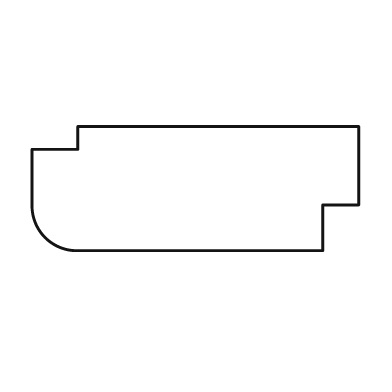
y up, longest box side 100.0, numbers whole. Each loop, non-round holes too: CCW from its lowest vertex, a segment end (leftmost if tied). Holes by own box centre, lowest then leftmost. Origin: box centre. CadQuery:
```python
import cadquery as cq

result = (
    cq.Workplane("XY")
    .moveTo(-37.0, -19.0)
    .lineTo(39.0, -19.0)
    .lineTo(39.0, -5.0)
    .lineTo(50.0, -5.0)
    .lineTo(50.0, 19.0)
    .lineTo(-36.0, 19.0)
    .lineTo(-36.0, 12.0)
    .lineTo(-50.0, 12.0)
    .lineTo(-50.0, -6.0)
    .threePointArc((-46.0, -15.0), (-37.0, -19.0))
    .close()
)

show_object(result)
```